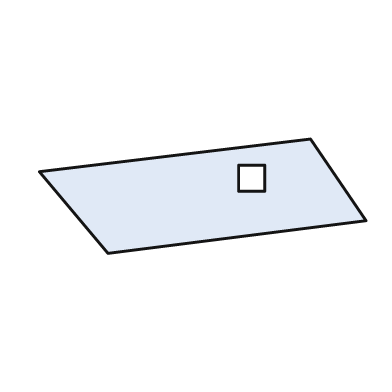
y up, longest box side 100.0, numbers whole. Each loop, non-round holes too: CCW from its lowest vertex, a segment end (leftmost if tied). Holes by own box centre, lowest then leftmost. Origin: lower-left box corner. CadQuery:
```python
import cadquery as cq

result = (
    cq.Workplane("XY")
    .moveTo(21.0, 0.0)
    .lineTo(100.0, 10.0)
    .lineTo(83.0, 35.0)
    .lineTo(0.0, 25.0)
    .close()
    .moveTo(61.0, 19.0)
    .lineTo(69.0, 19.0)
    .lineTo(69.0, 27.0)
    .lineTo(61.0, 27.0)
    .close()
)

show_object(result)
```